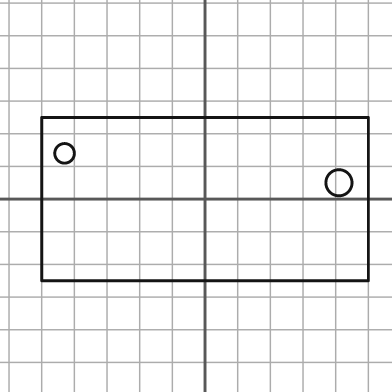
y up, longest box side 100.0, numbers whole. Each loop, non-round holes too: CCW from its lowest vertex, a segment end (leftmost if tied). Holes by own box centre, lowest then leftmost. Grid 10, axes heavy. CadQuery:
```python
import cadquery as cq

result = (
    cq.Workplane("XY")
    .moveTo(-50.0, -25.0)
    .lineTo(50.0, -25.0)
    .lineTo(50.0, 25.0)
    .lineTo(-50.0, 25.0)
    .close()
    .moveTo(41.0, 5.0)
    .circle(4.0)
    .moveTo(-43.0, 14.0)
    .circle(3.0)
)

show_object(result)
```